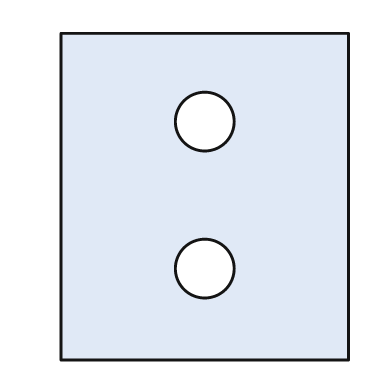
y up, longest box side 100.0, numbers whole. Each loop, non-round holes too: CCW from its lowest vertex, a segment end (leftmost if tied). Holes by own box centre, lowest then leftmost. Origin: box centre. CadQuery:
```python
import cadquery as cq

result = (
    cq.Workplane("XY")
    .moveTo(-44.0, -50.0)
    .lineTo(44.0, -50.0)
    .lineTo(44.0, 50.0)
    .lineTo(-44.0, 50.0)
    .close()
    .moveTo(0.0, -22.0)
    .circle(9.0)
    .moveTo(0.0, 23.0)
    .circle(9.0)
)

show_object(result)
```